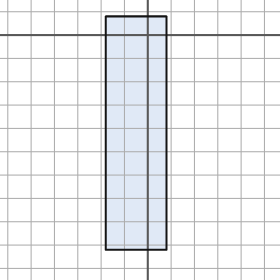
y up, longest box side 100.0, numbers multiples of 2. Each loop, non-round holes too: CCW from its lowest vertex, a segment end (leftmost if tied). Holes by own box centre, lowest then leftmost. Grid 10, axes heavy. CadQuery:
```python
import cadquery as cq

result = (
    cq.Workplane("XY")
    .moveTo(-18.0, -92.0)
    .lineTo(8.0, -92.0)
    .lineTo(8.0, 8.0)
    .lineTo(-18.0, 8.0)
    .close()
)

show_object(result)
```